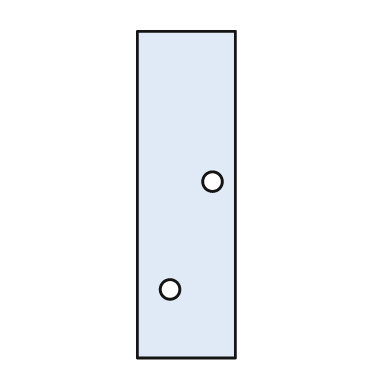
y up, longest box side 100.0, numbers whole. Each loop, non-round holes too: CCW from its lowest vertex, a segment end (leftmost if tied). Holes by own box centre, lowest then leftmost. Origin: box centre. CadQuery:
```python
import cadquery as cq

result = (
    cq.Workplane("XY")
    .moveTo(-15.0, -50.0)
    .lineTo(15.0, -50.0)
    .lineTo(15.0, 50.0)
    .lineTo(-15.0, 50.0)
    .close()
    .moveTo(-5.0, -29.0)
    .circle(3.0)
    .moveTo(8.0, 4.0)
    .circle(3.0)
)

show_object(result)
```